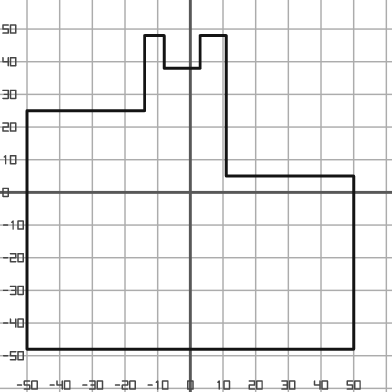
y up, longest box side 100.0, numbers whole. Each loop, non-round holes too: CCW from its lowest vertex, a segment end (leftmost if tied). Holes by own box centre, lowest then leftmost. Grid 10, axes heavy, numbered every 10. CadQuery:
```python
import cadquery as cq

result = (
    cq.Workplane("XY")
    .moveTo(-50.0, -48.0)
    .lineTo(50.0, -48.0)
    .lineTo(50.0, 5.0)
    .lineTo(11.0, 5.0)
    .lineTo(11.0, 48.0)
    .lineTo(3.0, 48.0)
    .lineTo(3.0, 38.0)
    .lineTo(-8.0, 38.0)
    .lineTo(-8.0, 48.0)
    .lineTo(-14.0, 48.0)
    .lineTo(-14.0, 25.0)
    .lineTo(-50.0, 25.0)
    .close()
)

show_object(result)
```